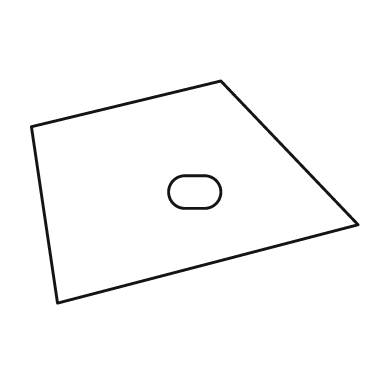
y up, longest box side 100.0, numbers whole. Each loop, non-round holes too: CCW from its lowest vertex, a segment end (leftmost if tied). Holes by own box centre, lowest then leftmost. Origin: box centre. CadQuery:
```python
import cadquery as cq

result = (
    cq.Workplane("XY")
    .moveTo(-42.0, -34.0)
    .lineTo(50.0, -10.0)
    .lineTo(8.0, 34.0)
    .lineTo(-50.0, 20.0)
    .close()
    .moveTo(-3.0, -5.0)
    .lineTo(3.0, -5.0)
    .threePointArc((8.0, 0.0), (3.0, 5.0))
    .lineTo(-3.0, 5.0)
    .threePointArc((-8.0, 0.0), (-3.0, -5.0))
    .close()
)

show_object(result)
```